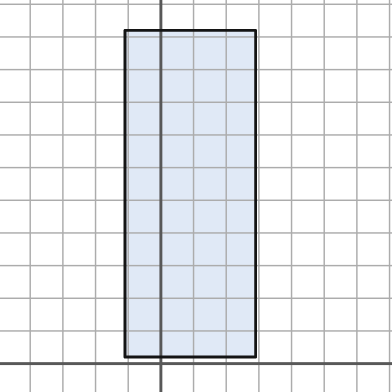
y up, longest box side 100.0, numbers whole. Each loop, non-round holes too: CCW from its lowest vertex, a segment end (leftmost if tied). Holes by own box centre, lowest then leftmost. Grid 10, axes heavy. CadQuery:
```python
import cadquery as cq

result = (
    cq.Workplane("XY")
    .moveTo(-11.0, 2.0)
    .lineTo(29.0, 2.0)
    .lineTo(29.0, 102.0)
    .lineTo(-11.0, 102.0)
    .close()
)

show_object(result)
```